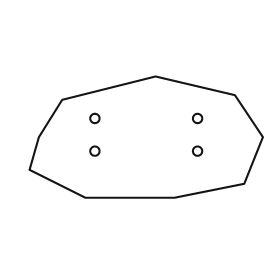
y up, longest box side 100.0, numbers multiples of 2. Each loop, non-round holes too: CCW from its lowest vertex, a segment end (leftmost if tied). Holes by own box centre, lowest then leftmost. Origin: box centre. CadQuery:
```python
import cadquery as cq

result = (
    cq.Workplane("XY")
    .moveTo(-26.0, -26.0)
    .lineTo(12.0, -26.0)
    .lineTo(42.0, -20.0)
    .lineTo(50.0, 0.0)
    .lineTo(38.0, 18.0)
    .lineTo(4.0, 26.0)
    .lineTo(-36.0, 16.0)
    .lineTo(-46.0, 0.0)
    .lineTo(-50.0, -14.0)
    .close()
    .moveTo(-22.0, -6.0)
    .circle(2.0)
    .moveTo(22.0, -6.0)
    .circle(2.0)
    .moveTo(-22.0, 8.0)
    .circle(2.0)
    .moveTo(22.0, 8.0)
    .circle(2.0)
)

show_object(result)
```